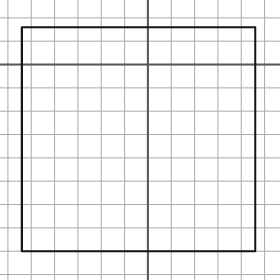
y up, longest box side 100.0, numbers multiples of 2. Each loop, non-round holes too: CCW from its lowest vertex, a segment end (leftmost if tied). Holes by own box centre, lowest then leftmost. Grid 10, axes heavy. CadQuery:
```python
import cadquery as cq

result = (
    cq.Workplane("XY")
    .moveTo(-54.0, -80.0)
    .lineTo(46.0, -80.0)
    .lineTo(46.0, 16.0)
    .lineTo(-54.0, 16.0)
    .close()
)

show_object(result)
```